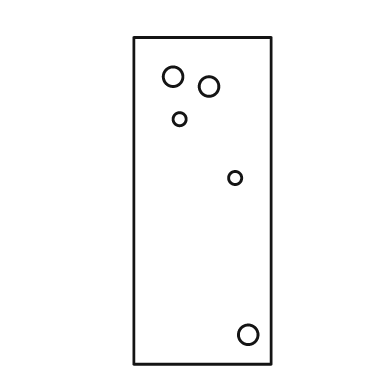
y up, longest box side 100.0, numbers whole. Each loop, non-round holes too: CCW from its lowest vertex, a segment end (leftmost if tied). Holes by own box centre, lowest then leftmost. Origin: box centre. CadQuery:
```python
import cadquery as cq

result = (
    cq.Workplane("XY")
    .moveTo(-21.0, -50.0)
    .lineTo(21.0, -50.0)
    .lineTo(21.0, 50.0)
    .lineTo(-21.0, 50.0)
    .close()
    .moveTo(14.0, -41.0)
    .circle(3.0)
    .moveTo(10.0, 7.0)
    .circle(2.0)
    .moveTo(-7.0, 25.0)
    .circle(2.0)
    .moveTo(2.0, 35.0)
    .circle(3.0)
    .moveTo(-9.0, 38.0)
    .circle(3.0)
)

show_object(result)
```